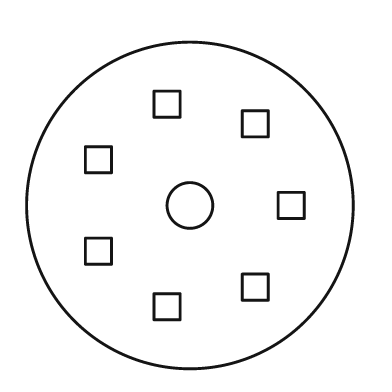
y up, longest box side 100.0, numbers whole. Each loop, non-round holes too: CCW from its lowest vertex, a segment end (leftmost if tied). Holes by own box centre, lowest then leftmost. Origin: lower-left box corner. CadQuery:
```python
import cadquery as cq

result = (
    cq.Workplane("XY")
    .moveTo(50.0, 50.0)
    .circle(50.0)
    .moveTo(39.0, 15.0)
    .lineTo(47.0, 15.0)
    .lineTo(47.0, 23.0)
    .lineTo(39.0, 23.0)
    .close()
    .moveTo(66.0, 21.0)
    .lineTo(74.0, 21.0)
    .lineTo(74.0, 29.0)
    .lineTo(66.0, 29.0)
    .close()
    .moveTo(18.0, 32.0)
    .lineTo(26.0, 32.0)
    .lineTo(26.0, 40.0)
    .lineTo(18.0, 40.0)
    .close()
    .moveTo(50.0, 50.0)
    .circle(7.0)
    .moveTo(77.0, 46.0)
    .lineTo(85.0, 46.0)
    .lineTo(85.0, 54.0)
    .lineTo(77.0, 54.0)
    .close()
    .moveTo(18.0, 60.0)
    .lineTo(26.0, 60.0)
    .lineTo(26.0, 68.0)
    .lineTo(18.0, 68.0)
    .close()
    .moveTo(66.0, 71.0)
    .lineTo(74.0, 71.0)
    .lineTo(74.0, 79.0)
    .lineTo(66.0, 79.0)
    .close()
    .moveTo(39.0, 77.0)
    .lineTo(47.0, 77.0)
    .lineTo(47.0, 85.0)
    .lineTo(39.0, 85.0)
    .close()
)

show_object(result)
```